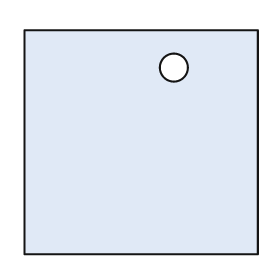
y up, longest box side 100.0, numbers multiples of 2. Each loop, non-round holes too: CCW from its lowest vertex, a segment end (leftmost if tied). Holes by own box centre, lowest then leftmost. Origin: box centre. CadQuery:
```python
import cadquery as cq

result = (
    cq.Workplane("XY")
    .moveTo(-50.0, -48.0)
    .lineTo(50.0, -48.0)
    .lineTo(50.0, 48.0)
    .lineTo(-50.0, 48.0)
    .close()
    .moveTo(14.0, 32.0)
    .circle(6.0)
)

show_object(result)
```